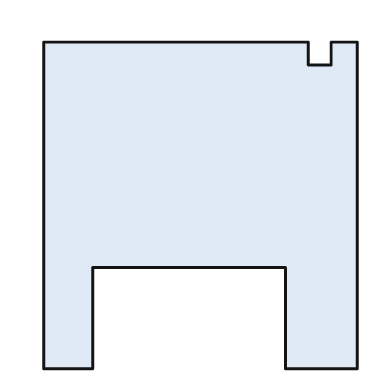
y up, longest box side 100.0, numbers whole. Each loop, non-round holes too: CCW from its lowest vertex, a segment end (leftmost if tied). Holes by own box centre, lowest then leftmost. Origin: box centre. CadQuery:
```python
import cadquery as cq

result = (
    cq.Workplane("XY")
    .moveTo(-48.0, -50.0)
    .lineTo(-33.0, -50.0)
    .lineTo(-33.0, -19.0)
    .lineTo(26.0, -19.0)
    .lineTo(26.0, -50.0)
    .lineTo(48.0, -50.0)
    .lineTo(48.0, 50.0)
    .lineTo(40.0, 50.0)
    .lineTo(40.0, 43.0)
    .lineTo(33.0, 43.0)
    .lineTo(33.0, 50.0)
    .lineTo(-48.0, 50.0)
    .close()
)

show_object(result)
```